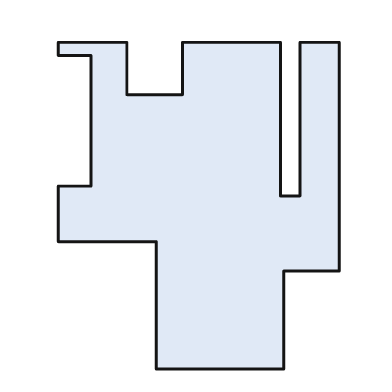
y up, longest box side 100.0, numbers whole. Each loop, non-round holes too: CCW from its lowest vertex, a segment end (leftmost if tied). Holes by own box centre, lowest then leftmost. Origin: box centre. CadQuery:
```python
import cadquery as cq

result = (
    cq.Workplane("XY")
    .moveTo(-13.0, -50.0)
    .lineTo(26.0, -50.0)
    .lineTo(26.0, -20.0)
    .lineTo(43.0, -20.0)
    .lineTo(43.0, 50.0)
    .lineTo(31.0, 50.0)
    .lineTo(31.0, 3.0)
    .lineTo(25.0, 3.0)
    .lineTo(25.0, 50.0)
    .lineTo(-5.0, 50.0)
    .lineTo(-5.0, 34.0)
    .lineTo(-22.0, 34.0)
    .lineTo(-22.0, 50.0)
    .lineTo(-43.0, 50.0)
    .lineTo(-43.0, 46.0)
    .lineTo(-33.0, 46.0)
    .lineTo(-33.0, 6.0)
    .lineTo(-43.0, 6.0)
    .lineTo(-43.0, -11.0)
    .lineTo(-13.0, -11.0)
    .close()
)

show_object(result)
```